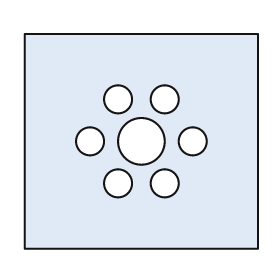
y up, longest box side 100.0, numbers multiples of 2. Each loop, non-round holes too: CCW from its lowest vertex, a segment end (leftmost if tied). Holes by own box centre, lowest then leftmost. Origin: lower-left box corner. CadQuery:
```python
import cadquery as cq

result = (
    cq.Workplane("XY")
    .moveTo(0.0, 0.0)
    .lineTo(100.0, 0.0)
    .lineTo(100.0, 92.0)
    .lineTo(0.0, 92.0)
    .close()
    .moveTo(40.0, 28.0)
    .circle(6.0)
    .moveTo(60.0, 28.0)
    .circle(6.0)
    .moveTo(28.0, 46.0)
    .circle(6.0)
    .moveTo(50.0, 46.0)
    .circle(10.0)
    .moveTo(72.0, 46.0)
    .circle(6.0)
    .moveTo(40.0, 64.0)
    .circle(6.0)
    .moveTo(60.0, 64.0)
    .circle(6.0)
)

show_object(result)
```